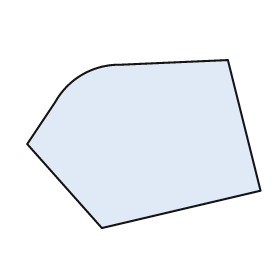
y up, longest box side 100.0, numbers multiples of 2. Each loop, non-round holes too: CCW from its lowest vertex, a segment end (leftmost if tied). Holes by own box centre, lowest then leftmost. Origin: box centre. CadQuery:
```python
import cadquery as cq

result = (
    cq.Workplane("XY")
    .moveTo(-18.0, -36.0)
    .lineTo(50.0, -20.0)
    .lineTo(36.0, 36.0)
    .lineTo(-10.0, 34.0)
    .threePointArc((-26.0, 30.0), (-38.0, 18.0))
    .lineTo(-50.0, 0.0)
    .close()
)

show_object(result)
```